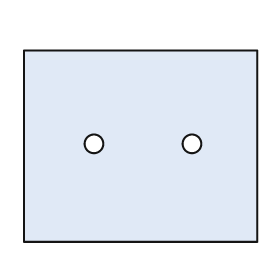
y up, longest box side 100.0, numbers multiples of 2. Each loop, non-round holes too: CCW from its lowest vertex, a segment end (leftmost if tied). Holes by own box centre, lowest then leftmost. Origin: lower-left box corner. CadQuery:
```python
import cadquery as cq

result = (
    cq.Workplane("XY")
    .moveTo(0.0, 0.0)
    .lineTo(100.0, 0.0)
    .lineTo(100.0, 82.0)
    .lineTo(0.0, 82.0)
    .close()
    .moveTo(30.0, 42.0)
    .circle(4.0)
    .moveTo(72.0, 42.0)
    .circle(4.0)
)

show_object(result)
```